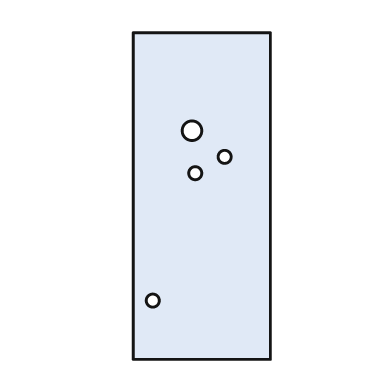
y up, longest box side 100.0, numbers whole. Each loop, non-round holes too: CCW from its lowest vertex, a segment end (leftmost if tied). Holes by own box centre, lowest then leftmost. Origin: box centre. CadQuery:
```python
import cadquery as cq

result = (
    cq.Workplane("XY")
    .moveTo(-21.0, -50.0)
    .lineTo(21.0, -50.0)
    .lineTo(21.0, 50.0)
    .lineTo(-21.0, 50.0)
    .close()
    .moveTo(-15.0, -32.0)
    .circle(2.0)
    .moveTo(-2.0, 7.0)
    .circle(2.0)
    .moveTo(7.0, 12.0)
    .circle(2.0)
    .moveTo(-3.0, 20.0)
    .circle(3.0)
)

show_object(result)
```